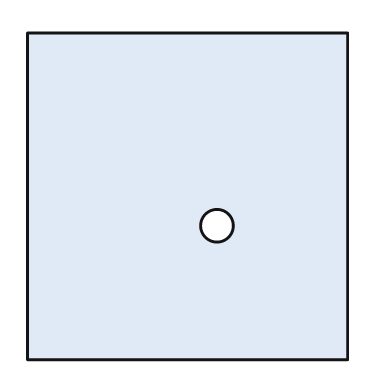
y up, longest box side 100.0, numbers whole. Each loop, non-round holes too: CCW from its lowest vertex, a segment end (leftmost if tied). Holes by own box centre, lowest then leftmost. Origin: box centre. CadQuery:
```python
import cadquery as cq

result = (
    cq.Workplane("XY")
    .moveTo(-49.0, -50.0)
    .lineTo(49.0, -50.0)
    .lineTo(49.0, 50.0)
    .lineTo(-49.0, 50.0)
    .close()
    .moveTo(9.0, -9.0)
    .circle(5.0)
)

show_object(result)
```